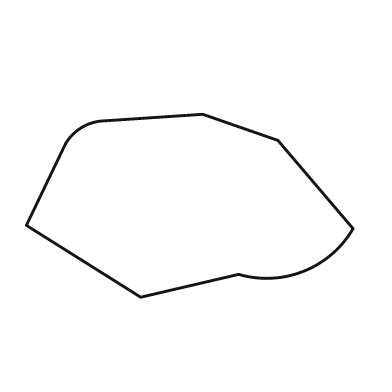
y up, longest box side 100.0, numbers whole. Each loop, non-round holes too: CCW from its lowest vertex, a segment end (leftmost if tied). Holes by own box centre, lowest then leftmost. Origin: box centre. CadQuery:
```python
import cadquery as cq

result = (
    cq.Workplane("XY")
    .moveTo(-15.0, -28.0)
    .lineTo(15.0, -21.0)
    .threePointArc((35.0, -20.0), (50.0, -7.0))
    .lineTo(27.0, 20.0)
    .lineTo(4.0, 28.0)
    .lineTo(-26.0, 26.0)
    .threePointArc((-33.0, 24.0), (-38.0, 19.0))
    .lineTo(-50.0, -6.0)
    .close()
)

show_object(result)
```